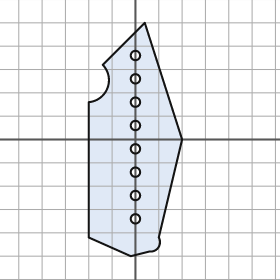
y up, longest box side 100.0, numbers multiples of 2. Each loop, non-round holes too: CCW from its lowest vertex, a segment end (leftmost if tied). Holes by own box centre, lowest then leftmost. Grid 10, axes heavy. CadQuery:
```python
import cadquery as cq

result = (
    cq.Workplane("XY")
    .moveTo(-2.0, -50.0)
    .lineTo(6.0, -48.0)
    .threePointArc((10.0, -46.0), (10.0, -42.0))
    .lineTo(20.0, 0.0)
    .lineTo(4.0, 50.0)
    .lineTo(-14.0, 32.0)
    .threePointArc((-12.0, 22.0), (-20.0, 16.0))
    .lineTo(-20.0, -42.0)
    .close()
    .moveTo(0.0, -34.0)
    .circle(2.0)
    .moveTo(0.0, -24.0)
    .circle(2.0)
    .moveTo(0.0, -14.0)
    .circle(2.0)
    .moveTo(0.0, -4.0)
    .circle(2.0)
    .moveTo(0.0, 6.0)
    .circle(2.0)
    .moveTo(0.0, 16.0)
    .circle(2.0)
    .moveTo(0.0, 26.0)
    .circle(2.0)
    .moveTo(0.0, 36.0)
    .circle(2.0)
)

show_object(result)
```